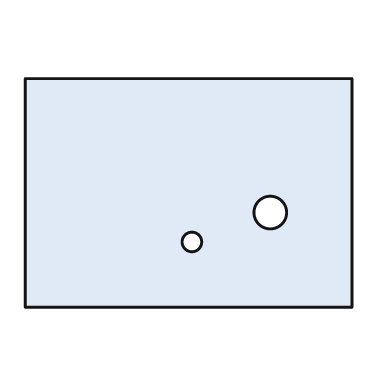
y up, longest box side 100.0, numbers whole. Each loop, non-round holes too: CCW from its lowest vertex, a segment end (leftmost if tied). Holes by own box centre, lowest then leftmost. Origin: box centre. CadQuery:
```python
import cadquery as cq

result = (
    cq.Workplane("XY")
    .moveTo(-50.0, -35.0)
    .lineTo(50.0, -35.0)
    .lineTo(50.0, 35.0)
    .lineTo(-50.0, 35.0)
    .close()
    .moveTo(1.0, -15.0)
    .circle(3.0)
    .moveTo(25.0, -6.0)
    .circle(5.0)
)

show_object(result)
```